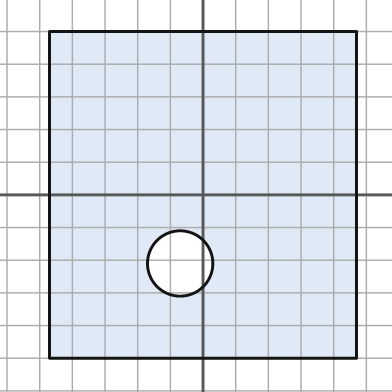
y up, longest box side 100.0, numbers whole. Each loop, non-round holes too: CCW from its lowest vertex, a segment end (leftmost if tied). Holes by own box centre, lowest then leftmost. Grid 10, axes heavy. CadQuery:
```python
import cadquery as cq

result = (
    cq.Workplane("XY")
    .moveTo(-47.0, -50.0)
    .lineTo(47.0, -50.0)
    .lineTo(47.0, 50.0)
    .lineTo(-47.0, 50.0)
    .close()
    .moveTo(-7.0, -21.0)
    .circle(10.0)
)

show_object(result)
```